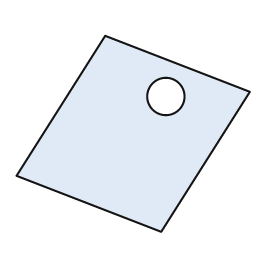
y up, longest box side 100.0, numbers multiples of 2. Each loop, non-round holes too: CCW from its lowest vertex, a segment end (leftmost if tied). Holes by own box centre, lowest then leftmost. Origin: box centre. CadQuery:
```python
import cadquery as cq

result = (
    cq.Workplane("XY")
    .moveTo(12.0, -42.0)
    .lineTo(50.0, 18.0)
    .lineTo(-12.0, 42.0)
    .lineTo(-50.0, -18.0)
    .close()
    .moveTo(14.0, 16.0)
    .circle(8.0)
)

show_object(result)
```